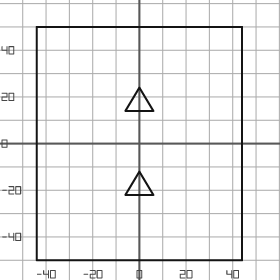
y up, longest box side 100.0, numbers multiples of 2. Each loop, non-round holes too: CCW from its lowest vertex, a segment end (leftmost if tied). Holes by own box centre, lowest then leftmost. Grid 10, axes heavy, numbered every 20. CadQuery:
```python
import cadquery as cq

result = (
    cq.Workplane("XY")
    .moveTo(-44.0, -50.0)
    .lineTo(44.0, -50.0)
    .lineTo(44.0, 50.0)
    .lineTo(-44.0, 50.0)
    .close()
    .moveTo(-6.0, -22.0)
    .lineTo(6.0, -22.0)
    .lineTo(0.0, -12.0)
    .close()
    .moveTo(-6.0, 14.0)
    .lineTo(6.0, 14.0)
    .lineTo(0.0, 24.0)
    .close()
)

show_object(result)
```